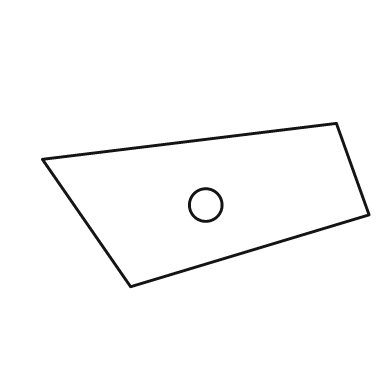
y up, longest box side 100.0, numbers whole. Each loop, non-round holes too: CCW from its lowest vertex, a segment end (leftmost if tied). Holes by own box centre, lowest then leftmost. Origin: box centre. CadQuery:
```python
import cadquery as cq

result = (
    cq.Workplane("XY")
    .moveTo(-23.0, -25.0)
    .lineTo(50.0, -3.0)
    .lineTo(40.0, 25.0)
    .lineTo(-50.0, 14.0)
    .close()
    .moveTo(0.0, 0.0)
    .circle(5.0)
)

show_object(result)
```